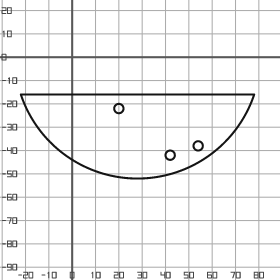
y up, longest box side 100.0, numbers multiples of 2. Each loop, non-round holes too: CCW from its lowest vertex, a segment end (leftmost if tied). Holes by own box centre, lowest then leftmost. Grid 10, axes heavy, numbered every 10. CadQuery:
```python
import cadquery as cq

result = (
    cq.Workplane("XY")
    .moveTo(-22.0, -16.0)
    .threePointArc((28.0, -52.0), (78.0, -16.0))
    .close()
    .moveTo(42.0, -42.0)
    .circle(2.0)
    .moveTo(54.0, -38.0)
    .circle(2.0)
    .moveTo(20.0, -22.0)
    .circle(2.0)
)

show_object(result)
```